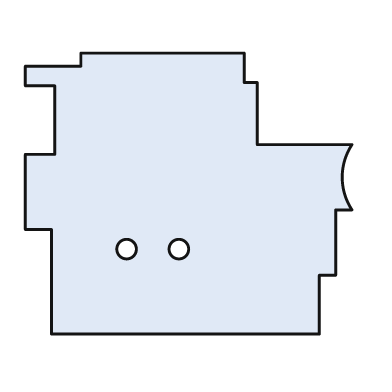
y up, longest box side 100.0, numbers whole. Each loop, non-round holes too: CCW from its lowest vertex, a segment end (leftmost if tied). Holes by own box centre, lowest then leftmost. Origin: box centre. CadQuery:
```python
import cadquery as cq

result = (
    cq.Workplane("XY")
    .moveTo(-42.0, -43.0)
    .lineTo(40.0, -43.0)
    .lineTo(40.0, -25.0)
    .lineTo(45.0, -25.0)
    .lineTo(45.0, -5.0)
    .lineTo(50.0, -5.0)
    .threePointArc((47.0, 5.0), (50.0, 15.0))
    .lineTo(21.0, 15.0)
    .lineTo(21.0, 34.0)
    .lineTo(17.0, 34.0)
    .lineTo(17.0, 43.0)
    .lineTo(-33.0, 43.0)
    .lineTo(-33.0, 39.0)
    .lineTo(-50.0, 39.0)
    .lineTo(-50.0, 33.0)
    .lineTo(-41.0, 33.0)
    .lineTo(-41.0, 12.0)
    .lineTo(-50.0, 12.0)
    .lineTo(-50.0, -11.0)
    .lineTo(-42.0, -11.0)
    .close()
    .moveTo(-19.0, -17.0)
    .circle(3.0)
    .moveTo(-3.0, -17.0)
    .circle(3.0)
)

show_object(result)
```